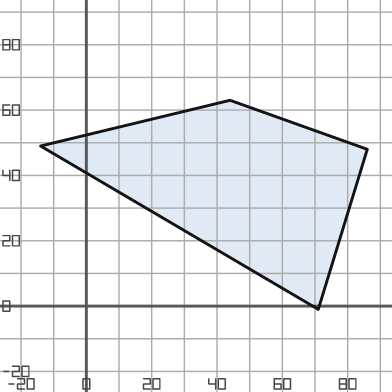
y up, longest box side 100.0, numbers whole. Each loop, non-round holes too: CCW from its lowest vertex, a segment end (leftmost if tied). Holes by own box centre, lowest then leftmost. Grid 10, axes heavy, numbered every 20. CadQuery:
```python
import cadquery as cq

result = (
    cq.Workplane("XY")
    .moveTo(71.0, -1.0)
    .lineTo(86.0, 48.0)
    .lineTo(44.0, 63.0)
    .lineTo(-14.0, 49.0)
    .close()
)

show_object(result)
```